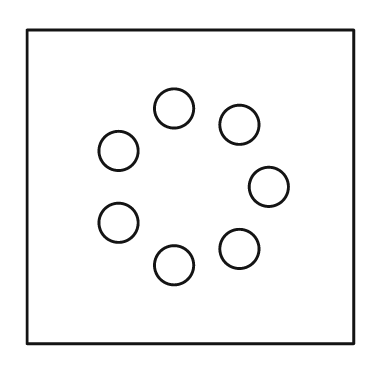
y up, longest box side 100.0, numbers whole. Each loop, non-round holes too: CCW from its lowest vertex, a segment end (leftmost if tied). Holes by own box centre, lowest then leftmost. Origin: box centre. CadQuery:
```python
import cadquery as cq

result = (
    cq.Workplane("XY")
    .moveTo(-50.0, -48.0)
    .lineTo(50.0, -48.0)
    .lineTo(50.0, 48.0)
    .lineTo(-50.0, 48.0)
    .close()
    .moveTo(-5.0, -24.0)
    .circle(6.0)
    .moveTo(15.0, -19.0)
    .circle(6.0)
    .moveTo(-22.0, -11.0)
    .circle(6.0)
    .moveTo(24.0, 0.0)
    .circle(6.0)
    .moveTo(-22.0, 11.0)
    .circle(6.0)
    .moveTo(15.0, 19.0)
    .circle(6.0)
    .moveTo(-5.0, 24.0)
    .circle(6.0)
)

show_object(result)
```